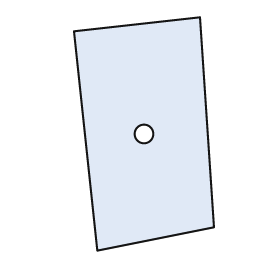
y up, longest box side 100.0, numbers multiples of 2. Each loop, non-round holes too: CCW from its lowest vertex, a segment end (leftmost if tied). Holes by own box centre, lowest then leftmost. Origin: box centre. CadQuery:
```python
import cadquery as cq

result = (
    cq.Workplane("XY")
    .moveTo(-20.0, -50.0)
    .lineTo(30.0, -40.0)
    .lineTo(24.0, 50.0)
    .lineTo(-30.0, 44.0)
    .close()
    .moveTo(0.0, 0.0)
    .circle(4.0)
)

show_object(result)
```